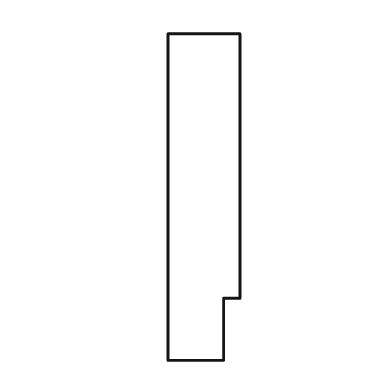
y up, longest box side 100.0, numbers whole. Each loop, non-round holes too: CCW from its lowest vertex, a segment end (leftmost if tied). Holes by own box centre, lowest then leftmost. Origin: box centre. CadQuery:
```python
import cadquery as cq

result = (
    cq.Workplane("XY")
    .moveTo(-11.0, -50.0)
    .lineTo(6.0, -50.0)
    .lineTo(6.0, -31.0)
    .lineTo(11.0, -31.0)
    .lineTo(11.0, 50.0)
    .lineTo(-11.0, 50.0)
    .close()
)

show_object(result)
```